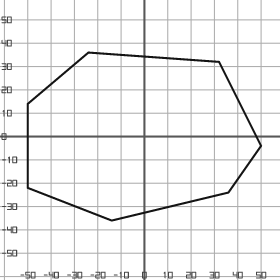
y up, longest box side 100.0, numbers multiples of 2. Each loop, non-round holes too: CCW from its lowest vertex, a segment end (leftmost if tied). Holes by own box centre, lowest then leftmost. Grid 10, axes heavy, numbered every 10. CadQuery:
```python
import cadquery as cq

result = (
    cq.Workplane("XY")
    .moveTo(-14.0, -36.0)
    .lineTo(36.0, -24.0)
    .lineTo(50.0, -4.0)
    .lineTo(32.0, 32.0)
    .lineTo(-24.0, 36.0)
    .lineTo(-50.0, 14.0)
    .lineTo(-50.0, -22.0)
    .close()
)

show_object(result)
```